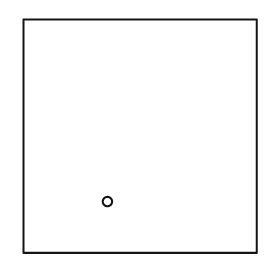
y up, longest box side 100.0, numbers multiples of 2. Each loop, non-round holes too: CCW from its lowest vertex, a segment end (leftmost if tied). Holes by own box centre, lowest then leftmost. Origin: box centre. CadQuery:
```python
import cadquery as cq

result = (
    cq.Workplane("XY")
    .moveTo(-50.0, -50.0)
    .lineTo(50.0, -50.0)
    .lineTo(50.0, 50.0)
    .lineTo(-50.0, 50.0)
    .close()
    .moveTo(-14.0, -28.0)
    .circle(2.0)
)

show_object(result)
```